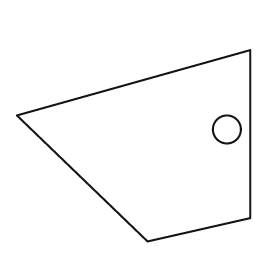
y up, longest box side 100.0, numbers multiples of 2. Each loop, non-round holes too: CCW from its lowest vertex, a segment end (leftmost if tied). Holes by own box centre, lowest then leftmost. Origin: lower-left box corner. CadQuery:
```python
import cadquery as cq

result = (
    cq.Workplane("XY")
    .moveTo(56.0, 0.0)
    .lineTo(100.0, 10.0)
    .lineTo(100.0, 82.0)
    .lineTo(0.0, 54.0)
    .close()
    .moveTo(90.0, 48.0)
    .circle(6.0)
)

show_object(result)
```